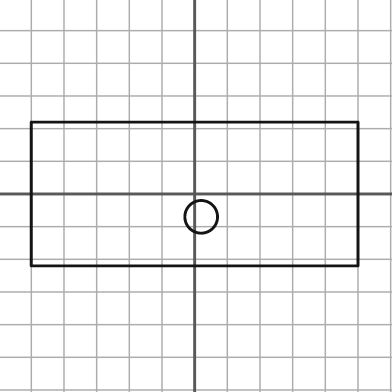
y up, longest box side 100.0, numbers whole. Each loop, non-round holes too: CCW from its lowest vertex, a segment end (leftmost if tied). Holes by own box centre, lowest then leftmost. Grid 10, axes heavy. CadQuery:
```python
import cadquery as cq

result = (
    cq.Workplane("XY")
    .moveTo(-50.0, -22.0)
    .lineTo(50.0, -22.0)
    .lineTo(50.0, 22.0)
    .lineTo(-50.0, 22.0)
    .close()
    .moveTo(2.0, -7.0)
    .circle(5.0)
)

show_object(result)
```